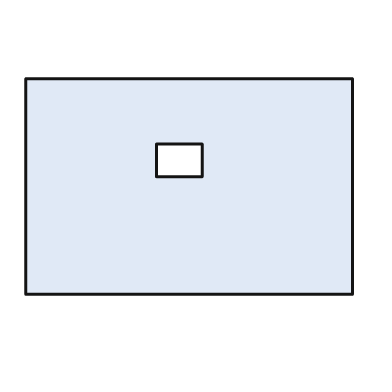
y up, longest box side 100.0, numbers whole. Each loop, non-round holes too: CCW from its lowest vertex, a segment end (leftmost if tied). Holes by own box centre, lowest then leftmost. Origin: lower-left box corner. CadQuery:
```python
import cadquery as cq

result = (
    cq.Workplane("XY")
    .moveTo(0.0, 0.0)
    .lineTo(100.0, 0.0)
    .lineTo(100.0, 66.0)
    .lineTo(0.0, 66.0)
    .close()
    .moveTo(40.0, 36.0)
    .lineTo(54.0, 36.0)
    .lineTo(54.0, 46.0)
    .lineTo(40.0, 46.0)
    .close()
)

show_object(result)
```